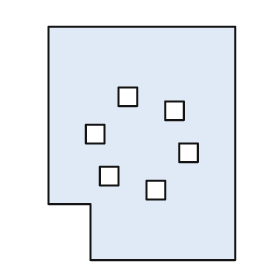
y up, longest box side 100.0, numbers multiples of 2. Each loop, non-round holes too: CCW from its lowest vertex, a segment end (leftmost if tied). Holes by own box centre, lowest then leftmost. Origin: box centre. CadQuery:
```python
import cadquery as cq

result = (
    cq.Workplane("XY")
    .moveTo(-22.0, -50.0)
    .lineTo(40.0, -50.0)
    .lineTo(40.0, 50.0)
    .lineTo(-40.0, 50.0)
    .lineTo(-40.0, -26.0)
    .lineTo(-22.0, -26.0)
    .close()
    .moveTo(2.0, -24.0)
    .lineTo(10.0, -24.0)
    .lineTo(10.0, -16.0)
    .lineTo(2.0, -16.0)
    .close()
    .moveTo(-18.0, -18.0)
    .lineTo(-10.0, -18.0)
    .lineTo(-10.0, -10.0)
    .lineTo(-18.0, -10.0)
    .close()
    .moveTo(16.0, -8.0)
    .lineTo(24.0, -8.0)
    .lineTo(24.0, 0.0)
    .lineTo(16.0, 0.0)
    .close()
    .moveTo(-24.0, 0.0)
    .lineTo(-16.0, 0.0)
    .lineTo(-16.0, 8.0)
    .lineTo(-24.0, 8.0)
    .close()
    .moveTo(10.0, 10.0)
    .lineTo(18.0, 10.0)
    .lineTo(18.0, 18.0)
    .lineTo(10.0, 18.0)
    .close()
    .moveTo(-10.0, 16.0)
    .lineTo(-2.0, 16.0)
    .lineTo(-2.0, 24.0)
    .lineTo(-10.0, 24.0)
    .close()
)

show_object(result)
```